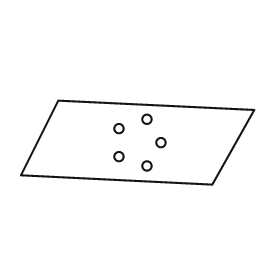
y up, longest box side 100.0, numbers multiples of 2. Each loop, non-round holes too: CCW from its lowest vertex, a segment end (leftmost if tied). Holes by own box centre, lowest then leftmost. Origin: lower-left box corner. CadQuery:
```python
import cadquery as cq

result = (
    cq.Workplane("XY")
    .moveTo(82.0, 0.0)
    .lineTo(100.0, 32.0)
    .lineTo(16.0, 36.0)
    .lineTo(0.0, 4.0)
    .close()
    .moveTo(54.0, 8.0)
    .circle(2.0)
    .moveTo(42.0, 12.0)
    .circle(2.0)
    .moveTo(60.0, 18.0)
    .circle(2.0)
    .moveTo(42.0, 24.0)
    .circle(2.0)
    .moveTo(54.0, 28.0)
    .circle(2.0)
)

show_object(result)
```